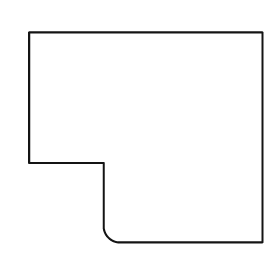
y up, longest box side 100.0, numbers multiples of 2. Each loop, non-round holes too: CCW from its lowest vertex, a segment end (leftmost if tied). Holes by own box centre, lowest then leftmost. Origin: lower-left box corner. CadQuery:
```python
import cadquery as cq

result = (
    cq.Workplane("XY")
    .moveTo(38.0, 0.0)
    .lineTo(100.0, 0.0)
    .lineTo(100.0, 90.0)
    .lineTo(0.0, 90.0)
    .lineTo(0.0, 34.0)
    .lineTo(32.0, 34.0)
    .lineTo(32.0, 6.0)
    .threePointArc((34.0, 2.0), (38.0, 0.0))
    .close()
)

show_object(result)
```